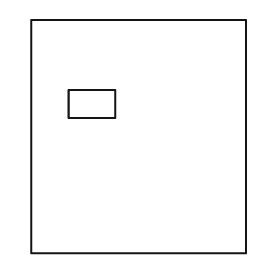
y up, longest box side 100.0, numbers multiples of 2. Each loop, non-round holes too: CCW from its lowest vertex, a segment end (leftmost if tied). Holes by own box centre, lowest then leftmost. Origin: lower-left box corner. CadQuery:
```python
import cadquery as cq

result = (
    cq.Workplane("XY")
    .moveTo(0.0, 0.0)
    .lineTo(92.0, 0.0)
    .lineTo(92.0, 100.0)
    .lineTo(0.0, 100.0)
    .close()
    .moveTo(16.0, 58.0)
    .lineTo(36.0, 58.0)
    .lineTo(36.0, 70.0)
    .lineTo(16.0, 70.0)
    .close()
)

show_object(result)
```